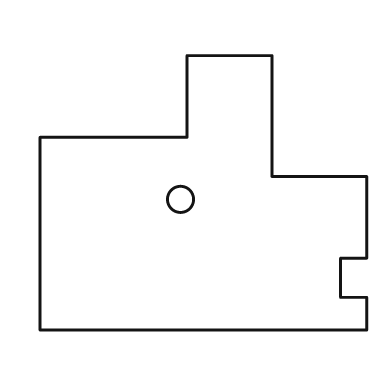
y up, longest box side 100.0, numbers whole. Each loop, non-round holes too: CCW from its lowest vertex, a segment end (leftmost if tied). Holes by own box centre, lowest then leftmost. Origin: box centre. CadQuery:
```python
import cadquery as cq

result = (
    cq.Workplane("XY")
    .moveTo(-50.0, -42.0)
    .lineTo(50.0, -42.0)
    .lineTo(50.0, -32.0)
    .lineTo(42.0, -32.0)
    .lineTo(42.0, -20.0)
    .lineTo(50.0, -20.0)
    .lineTo(50.0, 5.0)
    .lineTo(21.0, 5.0)
    .lineTo(21.0, 42.0)
    .lineTo(-5.0, 42.0)
    .lineTo(-5.0, 17.0)
    .lineTo(-50.0, 17.0)
    .close()
    .moveTo(-7.0, -2.0)
    .circle(4.0)
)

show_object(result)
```